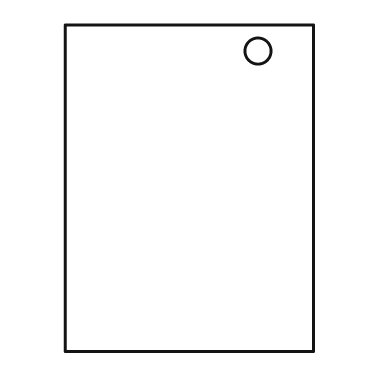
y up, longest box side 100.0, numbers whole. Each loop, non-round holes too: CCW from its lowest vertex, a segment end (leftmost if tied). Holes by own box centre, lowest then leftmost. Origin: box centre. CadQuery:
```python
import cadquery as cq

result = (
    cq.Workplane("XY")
    .moveTo(-38.0, -50.0)
    .lineTo(38.0, -50.0)
    .lineTo(38.0, 50.0)
    .lineTo(-38.0, 50.0)
    .close()
    .moveTo(21.0, 42.0)
    .circle(4.0)
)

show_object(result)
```